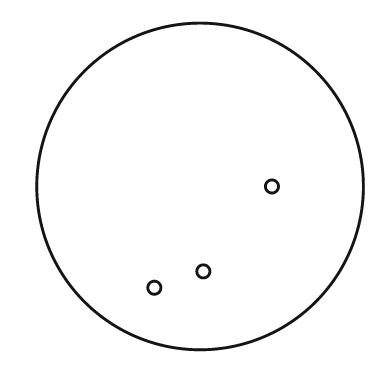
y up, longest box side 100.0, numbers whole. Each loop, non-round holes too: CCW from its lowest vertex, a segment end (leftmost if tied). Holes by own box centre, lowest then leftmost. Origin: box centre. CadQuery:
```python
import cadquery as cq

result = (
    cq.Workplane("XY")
    .moveTo(0.0, 0.0)
    .circle(50.0)
    .moveTo(-14.0, -31.0)
    .circle(2.0)
    .moveTo(1.0, -26.0)
    .circle(2.0)
    .moveTo(22.0, 0.0)
    .circle(2.0)
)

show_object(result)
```